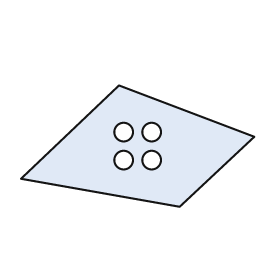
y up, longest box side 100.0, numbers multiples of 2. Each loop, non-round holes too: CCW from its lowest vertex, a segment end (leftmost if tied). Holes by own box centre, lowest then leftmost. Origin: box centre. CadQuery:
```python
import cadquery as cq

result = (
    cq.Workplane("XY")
    .moveTo(18.0, -26.0)
    .lineTo(50.0, 4.0)
    .lineTo(-8.0, 26.0)
    .lineTo(-50.0, -14.0)
    .close()
    .moveTo(-6.0, -6.0)
    .circle(4.0)
    .moveTo(6.0, -6.0)
    .circle(4.0)
    .moveTo(-6.0, 6.0)
    .circle(4.0)
    .moveTo(6.0, 6.0)
    .circle(4.0)
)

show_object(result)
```